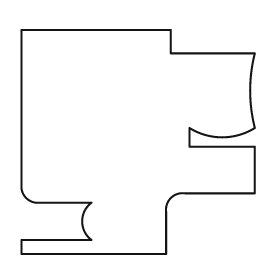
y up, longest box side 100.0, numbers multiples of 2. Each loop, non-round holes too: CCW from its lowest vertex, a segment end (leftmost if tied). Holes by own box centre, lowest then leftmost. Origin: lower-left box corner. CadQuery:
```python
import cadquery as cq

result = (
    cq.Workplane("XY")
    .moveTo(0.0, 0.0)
    .lineTo(62.0, 0.0)
    .lineTo(62.0, 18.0)
    .threePointArc((64.0, 24.0), (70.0, 26.0))
    .lineTo(100.0, 26.0)
    .lineTo(100.0, 46.0)
    .lineTo(72.0, 46.0)
    .lineTo(72.0, 54.0)
    .threePointArc((86.0, 50.0), (100.0, 54.0))
    .threePointArc((98.0, 70.0), (100.0, 86.0))
    .lineTo(64.0, 86.0)
    .lineTo(64.0, 96.0)
    .lineTo(0.0, 96.0)
    .lineTo(0.0, 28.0)
    .threePointArc((2.0, 24.0), (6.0, 22.0))
    .lineTo(30.0, 22.0)
    .threePointArc((26.0, 14.0), (30.0, 6.0))
    .lineTo(0.0, 6.0)
    .close()
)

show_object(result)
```